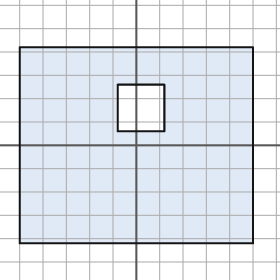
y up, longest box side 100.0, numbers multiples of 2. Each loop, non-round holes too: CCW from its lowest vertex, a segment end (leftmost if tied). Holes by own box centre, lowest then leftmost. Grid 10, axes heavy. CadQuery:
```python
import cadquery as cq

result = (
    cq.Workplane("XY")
    .moveTo(-50.0, -42.0)
    .lineTo(50.0, -42.0)
    .lineTo(50.0, 42.0)
    .lineTo(-50.0, 42.0)
    .close()
    .moveTo(-8.0, 6.0)
    .lineTo(12.0, 6.0)
    .lineTo(12.0, 26.0)
    .lineTo(-8.0, 26.0)
    .close()
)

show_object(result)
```